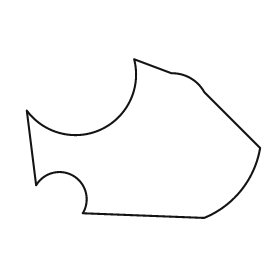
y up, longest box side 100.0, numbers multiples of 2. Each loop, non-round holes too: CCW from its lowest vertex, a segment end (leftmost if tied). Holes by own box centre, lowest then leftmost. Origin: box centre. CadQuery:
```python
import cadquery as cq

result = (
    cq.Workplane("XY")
    .moveTo(26.0, -34.0)
    .threePointArc((42.0, -22.0), (50.0, -4.0))
    .lineTo(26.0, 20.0)
    .threePointArc((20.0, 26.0), (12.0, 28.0))
    .lineTo(-4.0, 34.0)
    .threePointArc((-18.0, 4.0), (-50.0, 12.0))
    .lineTo(-46.0, -20.0)
    .threePointArc((-30.0, -16.0), (-26.0, -32.0))
    .close()
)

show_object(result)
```